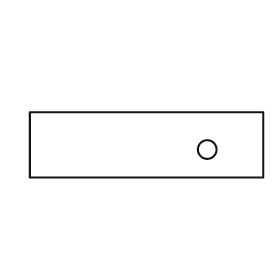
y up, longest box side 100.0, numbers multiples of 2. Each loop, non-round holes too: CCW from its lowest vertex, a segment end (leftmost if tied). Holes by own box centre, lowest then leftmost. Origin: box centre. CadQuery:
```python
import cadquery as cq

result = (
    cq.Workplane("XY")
    .moveTo(-50.0, -14.0)
    .lineTo(50.0, -14.0)
    .lineTo(50.0, 14.0)
    .lineTo(-50.0, 14.0)
    .close()
    .moveTo(26.0, -2.0)
    .circle(4.0)
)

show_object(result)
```